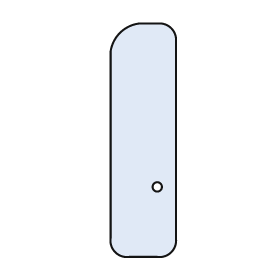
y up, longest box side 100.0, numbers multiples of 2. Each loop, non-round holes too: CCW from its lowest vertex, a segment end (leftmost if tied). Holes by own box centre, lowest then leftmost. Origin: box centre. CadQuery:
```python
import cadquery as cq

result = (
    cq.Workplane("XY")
    .moveTo(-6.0, -50.0)
    .lineTo(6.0, -50.0)
    .threePointArc((12.0, -48.0), (14.0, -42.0))
    .lineTo(14.0, 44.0)
    .threePointArc((12.0, 48.0), (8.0, 50.0))
    .lineTo(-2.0, 50.0)
    .threePointArc((-10.0, 46.0), (-14.0, 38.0))
    .lineTo(-14.0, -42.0)
    .threePointArc((-12.0, -48.0), (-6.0, -50.0))
    .close()
    .moveTo(6.0, -20.0)
    .circle(2.0)
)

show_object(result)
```